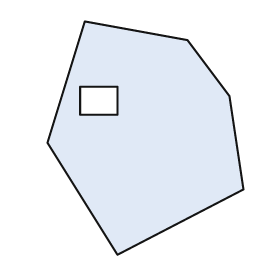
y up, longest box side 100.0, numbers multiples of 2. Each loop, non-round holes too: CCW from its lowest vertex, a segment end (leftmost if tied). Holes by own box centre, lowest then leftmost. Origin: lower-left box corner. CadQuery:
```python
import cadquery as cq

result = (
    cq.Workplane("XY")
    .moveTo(30.0, 0.0)
    .lineTo(84.0, 28.0)
    .lineTo(78.0, 68.0)
    .lineTo(60.0, 92.0)
    .lineTo(16.0, 100.0)
    .lineTo(0.0, 48.0)
    .close()
    .moveTo(14.0, 60.0)
    .lineTo(30.0, 60.0)
    .lineTo(30.0, 72.0)
    .lineTo(14.0, 72.0)
    .close()
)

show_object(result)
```